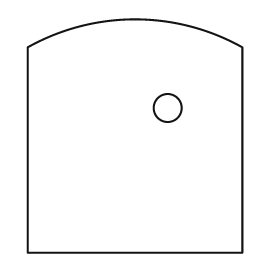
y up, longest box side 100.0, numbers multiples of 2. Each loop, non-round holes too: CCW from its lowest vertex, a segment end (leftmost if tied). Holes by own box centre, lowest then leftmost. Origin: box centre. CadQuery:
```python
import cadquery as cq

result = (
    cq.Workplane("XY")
    .moveTo(-46.0, -50.0)
    .lineTo(46.0, -50.0)
    .lineTo(46.0, 38.0)
    .threePointArc((0.0, 50.0), (-46.0, 38.0))
    .close()
    .moveTo(14.0, 12.0)
    .circle(6.0)
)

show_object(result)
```